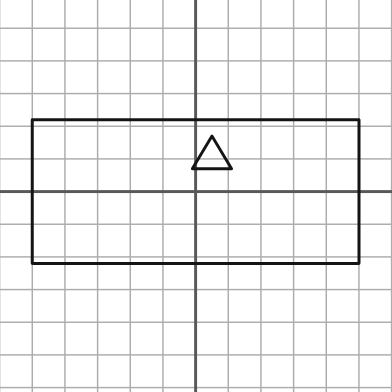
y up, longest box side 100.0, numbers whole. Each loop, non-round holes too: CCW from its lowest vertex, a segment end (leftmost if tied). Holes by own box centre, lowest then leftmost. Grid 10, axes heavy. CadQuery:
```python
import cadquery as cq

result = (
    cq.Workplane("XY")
    .moveTo(-50.0, -22.0)
    .lineTo(50.0, -22.0)
    .lineTo(50.0, 22.0)
    .lineTo(-50.0, 22.0)
    .close()
    .moveTo(-1.0, 7.0)
    .lineTo(11.0, 7.0)
    .lineTo(5.0, 17.0)
    .close()
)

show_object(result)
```